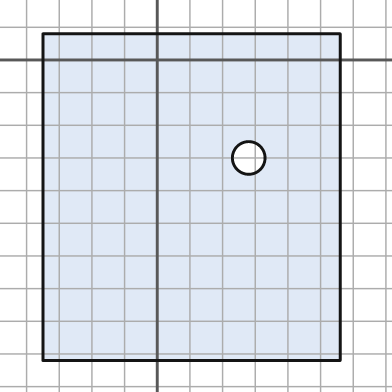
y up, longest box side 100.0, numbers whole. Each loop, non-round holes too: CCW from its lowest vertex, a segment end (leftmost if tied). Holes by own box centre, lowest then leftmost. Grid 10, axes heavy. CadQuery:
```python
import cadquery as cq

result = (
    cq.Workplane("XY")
    .moveTo(-35.0, -92.0)
    .lineTo(56.0, -92.0)
    .lineTo(56.0, 8.0)
    .lineTo(-35.0, 8.0)
    .close()
    .moveTo(28.0, -30.0)
    .circle(5.0)
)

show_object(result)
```